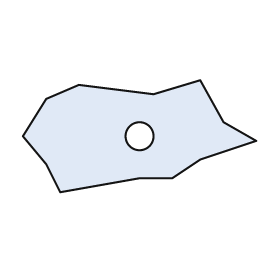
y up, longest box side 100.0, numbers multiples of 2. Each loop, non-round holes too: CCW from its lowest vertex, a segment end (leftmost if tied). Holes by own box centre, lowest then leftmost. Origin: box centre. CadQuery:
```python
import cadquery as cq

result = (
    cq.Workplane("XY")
    .moveTo(-34.0, -24.0)
    .lineTo(0.0, -18.0)
    .lineTo(14.0, -18.0)
    .lineTo(26.0, -10.0)
    .lineTo(50.0, -2.0)
    .lineTo(36.0, 6.0)
    .lineTo(26.0, 24.0)
    .lineTo(6.0, 18.0)
    .lineTo(-26.0, 22.0)
    .lineTo(-40.0, 16.0)
    .lineTo(-50.0, 0.0)
    .lineTo(-40.0, -12.0)
    .close()
    .moveTo(0.0, 0.0)
    .circle(6.0)
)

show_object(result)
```